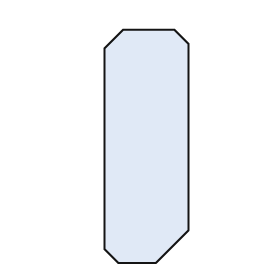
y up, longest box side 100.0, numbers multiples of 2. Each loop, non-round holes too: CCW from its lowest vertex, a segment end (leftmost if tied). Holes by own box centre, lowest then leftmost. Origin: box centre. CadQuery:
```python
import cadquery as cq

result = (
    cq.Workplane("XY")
    .moveTo(-12.0, -50.0)
    .lineTo(4.0, -50.0)
    .lineTo(18.0, -36.0)
    .lineTo(18.0, 44.0)
    .lineTo(12.0, 50.0)
    .lineTo(-10.0, 50.0)
    .lineTo(-18.0, 42.0)
    .lineTo(-18.0, -44.0)
    .close()
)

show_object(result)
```